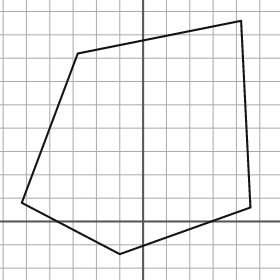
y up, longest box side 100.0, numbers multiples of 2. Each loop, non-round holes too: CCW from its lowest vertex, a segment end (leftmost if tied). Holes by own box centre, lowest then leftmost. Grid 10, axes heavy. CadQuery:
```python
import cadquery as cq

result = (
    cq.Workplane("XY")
    .moveTo(-10.0, -14.0)
    .lineTo(46.0, 6.0)
    .lineTo(42.0, 86.0)
    .lineTo(-28.0, 72.0)
    .lineTo(-52.0, 8.0)
    .close()
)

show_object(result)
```